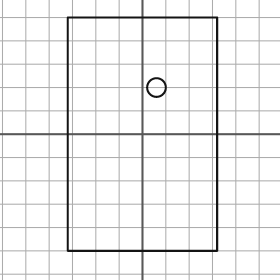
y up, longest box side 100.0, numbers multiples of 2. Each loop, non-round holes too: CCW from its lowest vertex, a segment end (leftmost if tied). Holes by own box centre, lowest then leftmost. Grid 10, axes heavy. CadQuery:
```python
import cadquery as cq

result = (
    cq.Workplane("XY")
    .moveTo(-32.0, -50.0)
    .lineTo(32.0, -50.0)
    .lineTo(32.0, 50.0)
    .lineTo(-32.0, 50.0)
    .close()
    .moveTo(6.0, 20.0)
    .circle(4.0)
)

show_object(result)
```